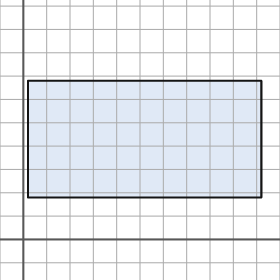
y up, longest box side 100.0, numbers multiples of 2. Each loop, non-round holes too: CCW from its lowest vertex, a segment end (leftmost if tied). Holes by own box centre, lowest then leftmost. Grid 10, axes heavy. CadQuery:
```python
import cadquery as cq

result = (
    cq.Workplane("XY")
    .moveTo(2.0, 18.0)
    .lineTo(102.0, 18.0)
    .lineTo(102.0, 68.0)
    .lineTo(2.0, 68.0)
    .close()
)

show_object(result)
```